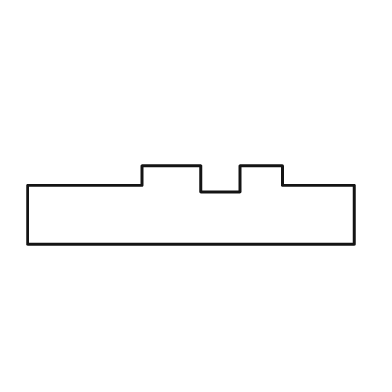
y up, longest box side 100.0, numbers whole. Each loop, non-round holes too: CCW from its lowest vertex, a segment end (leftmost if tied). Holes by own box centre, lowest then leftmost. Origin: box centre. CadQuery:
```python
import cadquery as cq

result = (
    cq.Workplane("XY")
    .moveTo(-50.0, -12.0)
    .lineTo(50.0, -12.0)
    .lineTo(50.0, 6.0)
    .lineTo(28.0, 6.0)
    .lineTo(28.0, 12.0)
    .lineTo(15.0, 12.0)
    .lineTo(15.0, 4.0)
    .lineTo(3.0, 4.0)
    .lineTo(3.0, 12.0)
    .lineTo(-15.0, 12.0)
    .lineTo(-15.0, 6.0)
    .lineTo(-50.0, 6.0)
    .close()
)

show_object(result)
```